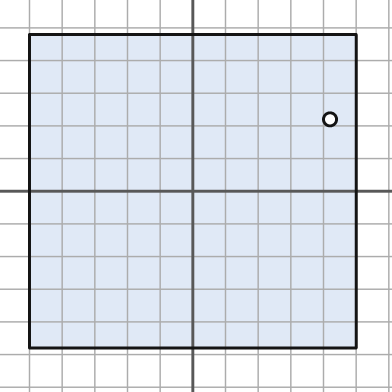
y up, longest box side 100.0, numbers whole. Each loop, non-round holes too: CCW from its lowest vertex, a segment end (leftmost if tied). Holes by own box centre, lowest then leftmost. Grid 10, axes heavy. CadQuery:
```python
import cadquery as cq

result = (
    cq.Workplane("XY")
    .moveTo(-50.0, -48.0)
    .lineTo(50.0, -48.0)
    .lineTo(50.0, 48.0)
    .lineTo(-50.0, 48.0)
    .close()
    .moveTo(42.0, 22.0)
    .circle(2.0)
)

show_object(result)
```